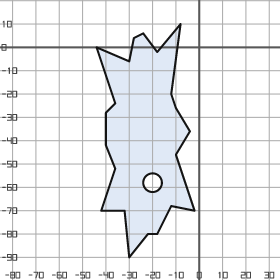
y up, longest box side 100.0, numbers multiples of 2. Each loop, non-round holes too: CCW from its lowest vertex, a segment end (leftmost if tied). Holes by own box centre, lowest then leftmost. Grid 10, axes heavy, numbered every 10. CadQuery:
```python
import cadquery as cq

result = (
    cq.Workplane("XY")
    .moveTo(-30.0, -90.0)
    .lineTo(-22.0, -80.0)
    .lineTo(-18.0, -80.0)
    .lineTo(-12.0, -68.0)
    .lineTo(-2.0, -70.0)
    .lineTo(-10.0, -46.0)
    .lineTo(-4.0, -36.0)
    .lineTo(-10.0, -26.0)
    .lineTo(-12.0, -20.0)
    .lineTo(-8.0, 10.0)
    .lineTo(-18.0, -2.0)
    .lineTo(-24.0, 6.0)
    .lineTo(-28.0, 4.0)
    .lineTo(-30.0, -6.0)
    .lineTo(-44.0, 0.0)
    .lineTo(-36.0, -24.0)
    .lineTo(-40.0, -28.0)
    .lineTo(-40.0, -42.0)
    .lineTo(-36.0, -52.0)
    .lineTo(-42.0, -70.0)
    .lineTo(-32.0, -70.0)
    .close()
    .moveTo(-20.0, -58.0)
    .circle(4.0)
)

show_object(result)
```